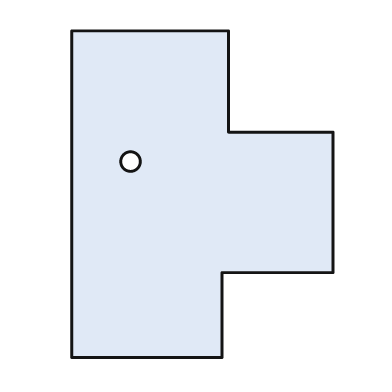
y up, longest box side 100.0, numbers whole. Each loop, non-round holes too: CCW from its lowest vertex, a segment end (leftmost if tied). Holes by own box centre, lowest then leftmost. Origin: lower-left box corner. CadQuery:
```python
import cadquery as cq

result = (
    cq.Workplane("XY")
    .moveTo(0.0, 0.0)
    .lineTo(46.0, 0.0)
    .lineTo(46.0, 26.0)
    .lineTo(80.0, 26.0)
    .lineTo(80.0, 69.0)
    .lineTo(48.0, 69.0)
    .lineTo(48.0, 100.0)
    .lineTo(0.0, 100.0)
    .close()
    .moveTo(18.0, 60.0)
    .circle(3.0)
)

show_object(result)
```